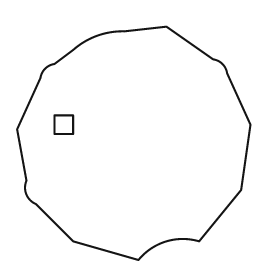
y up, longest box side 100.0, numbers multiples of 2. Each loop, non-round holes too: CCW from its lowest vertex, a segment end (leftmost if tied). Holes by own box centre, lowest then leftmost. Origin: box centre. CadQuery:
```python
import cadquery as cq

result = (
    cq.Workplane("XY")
    .moveTo(2.0, -50.0)
    .threePointArc((14.0, -42.0), (28.0, -42.0))
    .lineTo(46.0, -20.0)
    .lineTo(50.0, 8.0)
    .lineTo(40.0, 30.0)
    .threePointArc((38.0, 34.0), (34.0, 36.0))
    .lineTo(14.0, 50.0)
    .lineTo(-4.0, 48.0)
    .threePointArc((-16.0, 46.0), (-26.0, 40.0))
    .lineTo(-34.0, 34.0)
    .threePointArc((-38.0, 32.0), (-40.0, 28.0))
    .lineTo(-50.0, 6.0)
    .lineTo(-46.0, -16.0)
    .threePointArc((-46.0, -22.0), (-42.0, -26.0))
    .lineTo(-26.0, -42.0)
    .close()
    .moveTo(-34.0, 4.0)
    .lineTo(-26.0, 4.0)
    .lineTo(-26.0, 12.0)
    .lineTo(-34.0, 12.0)
    .close()
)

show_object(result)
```